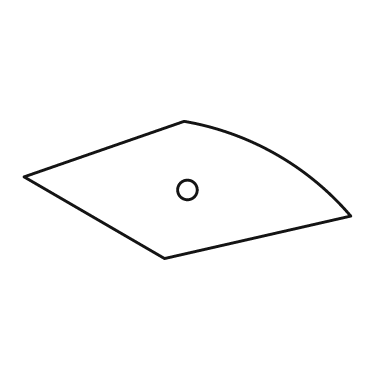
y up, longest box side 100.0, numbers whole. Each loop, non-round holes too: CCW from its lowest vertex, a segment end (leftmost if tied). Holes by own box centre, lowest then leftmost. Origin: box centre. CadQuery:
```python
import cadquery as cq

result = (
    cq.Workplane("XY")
    .moveTo(-7.0, -21.0)
    .lineTo(50.0, -8.0)
    .threePointArc((27.0, 11.0), (-1.0, 21.0))
    .lineTo(-50.0, 4.0)
    .close()
    .moveTo(0.0, 0.0)
    .circle(3.0)
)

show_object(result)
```